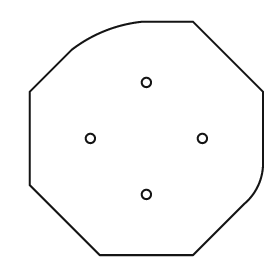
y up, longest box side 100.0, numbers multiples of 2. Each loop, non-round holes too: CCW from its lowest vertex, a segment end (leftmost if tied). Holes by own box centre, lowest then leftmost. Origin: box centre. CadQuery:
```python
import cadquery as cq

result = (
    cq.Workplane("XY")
    .moveTo(-20.0, -50.0)
    .lineTo(20.0, -50.0)
    .lineTo(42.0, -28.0)
    .threePointArc((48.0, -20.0), (50.0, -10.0))
    .lineTo(50.0, 20.0)
    .lineTo(20.0, 50.0)
    .lineTo(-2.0, 50.0)
    .threePointArc((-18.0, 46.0), (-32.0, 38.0))
    .lineTo(-50.0, 20.0)
    .lineTo(-50.0, -20.0)
    .close()
    .moveTo(0.0, -24.0)
    .circle(2.0)
    .moveTo(-24.0, 0.0)
    .circle(2.0)
    .moveTo(24.0, 0.0)
    .circle(2.0)
    .moveTo(0.0, 24.0)
    .circle(2.0)
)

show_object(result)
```